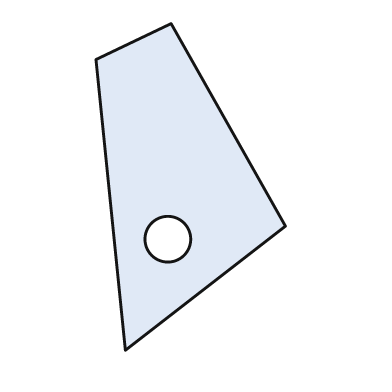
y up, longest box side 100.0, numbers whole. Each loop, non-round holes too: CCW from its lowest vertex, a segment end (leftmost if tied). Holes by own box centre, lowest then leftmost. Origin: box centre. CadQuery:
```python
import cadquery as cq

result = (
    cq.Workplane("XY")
    .moveTo(-20.0, -50.0)
    .lineTo(29.0, -12.0)
    .lineTo(-6.0, 50.0)
    .lineTo(-29.0, 39.0)
    .close()
    .moveTo(-7.0, -16.0)
    .circle(7.0)
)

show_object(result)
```